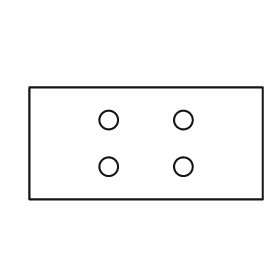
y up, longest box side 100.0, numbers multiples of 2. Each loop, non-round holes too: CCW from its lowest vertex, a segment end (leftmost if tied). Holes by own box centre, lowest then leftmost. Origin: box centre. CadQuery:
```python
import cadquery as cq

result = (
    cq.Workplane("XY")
    .moveTo(-50.0, -24.0)
    .lineTo(50.0, -24.0)
    .lineTo(50.0, 24.0)
    .lineTo(-50.0, 24.0)
    .close()
    .moveTo(-16.0, -10.0)
    .circle(4.0)
    .moveTo(16.0, -10.0)
    .circle(4.0)
    .moveTo(-16.0, 10.0)
    .circle(4.0)
    .moveTo(16.0, 10.0)
    .circle(4.0)
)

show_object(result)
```